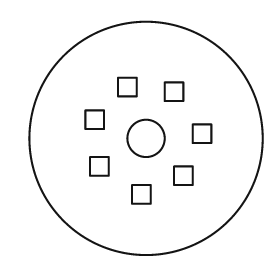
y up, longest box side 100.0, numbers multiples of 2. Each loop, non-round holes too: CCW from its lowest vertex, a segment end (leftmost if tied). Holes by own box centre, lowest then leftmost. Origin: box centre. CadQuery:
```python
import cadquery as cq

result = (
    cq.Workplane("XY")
    .moveTo(0.0, 0.0)
    .circle(50.0)
    .moveTo(-6.0, -28.0)
    .lineTo(2.0, -28.0)
    .lineTo(2.0, -20.0)
    .lineTo(-6.0, -20.0)
    .close()
    .moveTo(12.0, -20.0)
    .lineTo(20.0, -20.0)
    .lineTo(20.0, -12.0)
    .lineTo(12.0, -12.0)
    .close()
    .moveTo(-24.0, -16.0)
    .lineTo(-16.0, -16.0)
    .lineTo(-16.0, -8.0)
    .lineTo(-24.0, -8.0)
    .close()
    .moveTo(0.0, 0.0)
    .circle(8.0)
    .moveTo(20.0, -2.0)
    .lineTo(28.0, -2.0)
    .lineTo(28.0, 6.0)
    .lineTo(20.0, 6.0)
    .close()
    .moveTo(-26.0, 4.0)
    .lineTo(-18.0, 4.0)
    .lineTo(-18.0, 12.0)
    .lineTo(-26.0, 12.0)
    .close()
    .moveTo(8.0, 16.0)
    .lineTo(16.0, 16.0)
    .lineTo(16.0, 24.0)
    .lineTo(8.0, 24.0)
    .close()
    .moveTo(-12.0, 18.0)
    .lineTo(-4.0, 18.0)
    .lineTo(-4.0, 26.0)
    .lineTo(-12.0, 26.0)
    .close()
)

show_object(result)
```